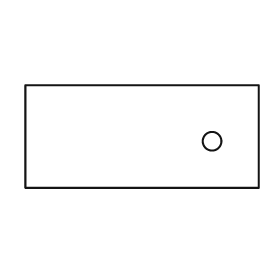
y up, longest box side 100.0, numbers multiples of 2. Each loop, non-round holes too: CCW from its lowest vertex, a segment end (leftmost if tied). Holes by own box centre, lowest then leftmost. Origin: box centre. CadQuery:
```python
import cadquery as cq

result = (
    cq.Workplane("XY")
    .moveTo(-50.0, -22.0)
    .lineTo(50.0, -22.0)
    .lineTo(50.0, 22.0)
    .lineTo(-50.0, 22.0)
    .close()
    .moveTo(30.0, -2.0)
    .circle(4.0)
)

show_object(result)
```